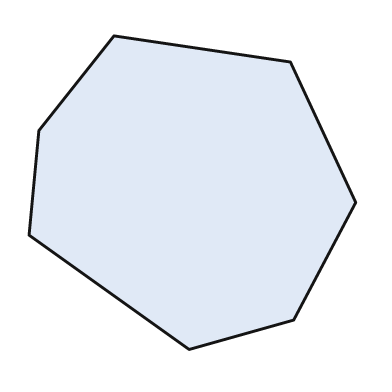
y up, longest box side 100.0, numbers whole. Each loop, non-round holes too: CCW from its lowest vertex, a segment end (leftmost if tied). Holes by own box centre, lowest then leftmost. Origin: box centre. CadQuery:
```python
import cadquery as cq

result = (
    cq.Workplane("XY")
    .moveTo(-1.0, -48.0)
    .lineTo(31.0, -39.0)
    .lineTo(50.0, -3.0)
    .lineTo(30.0, 40.0)
    .lineTo(-24.0, 48.0)
    .lineTo(-47.0, 19.0)
    .lineTo(-50.0, -13.0)
    .close()
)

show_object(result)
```